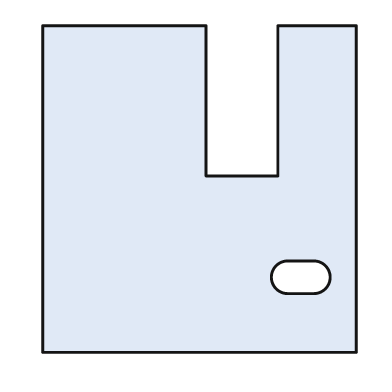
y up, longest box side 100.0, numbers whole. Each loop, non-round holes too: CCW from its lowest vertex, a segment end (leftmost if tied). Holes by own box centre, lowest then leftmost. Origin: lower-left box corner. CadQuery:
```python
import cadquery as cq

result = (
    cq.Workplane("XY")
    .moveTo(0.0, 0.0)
    .lineTo(96.0, 0.0)
    .lineTo(96.0, 100.0)
    .lineTo(72.0, 100.0)
    .lineTo(72.0, 54.0)
    .lineTo(50.0, 54.0)
    .lineTo(50.0, 100.0)
    .lineTo(0.0, 100.0)
    .close()
    .moveTo(75.0, 18.0)
    .lineTo(83.0, 18.0)
    .threePointArc((88.0, 23.0), (83.0, 28.0))
    .lineTo(75.0, 28.0)
    .threePointArc((70.0, 23.0), (75.0, 18.0))
    .close()
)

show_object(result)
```